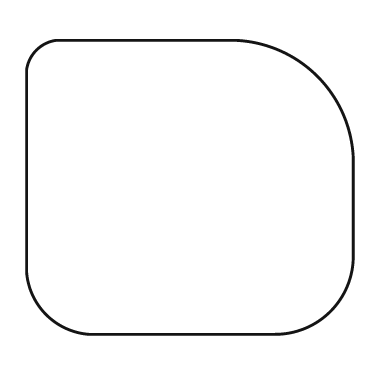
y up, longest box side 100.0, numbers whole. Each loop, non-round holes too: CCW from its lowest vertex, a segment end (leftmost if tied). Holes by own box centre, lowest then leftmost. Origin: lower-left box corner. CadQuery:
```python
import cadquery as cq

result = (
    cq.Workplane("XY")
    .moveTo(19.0, 0.0)
    .lineTo(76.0, 0.0)
    .threePointArc((93.0, 7.0), (100.0, 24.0))
    .lineTo(100.0, 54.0)
    .threePointArc((89.0, 79.0), (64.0, 90.0))
    .lineTo(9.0, 90.0)
    .threePointArc((3.0, 87.0), (0.0, 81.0))
    .lineTo(0.0, 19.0)
    .threePointArc((6.0, 6.0), (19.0, 0.0))
    .close()
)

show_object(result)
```